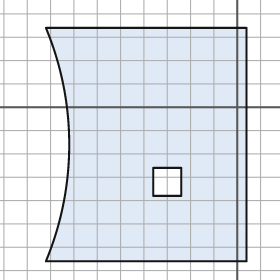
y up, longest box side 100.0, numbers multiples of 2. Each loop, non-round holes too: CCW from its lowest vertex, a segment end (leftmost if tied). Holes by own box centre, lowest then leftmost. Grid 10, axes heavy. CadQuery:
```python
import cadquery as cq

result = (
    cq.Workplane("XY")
    .moveTo(-82.0, -66.0)
    .lineTo(4.0, -66.0)
    .lineTo(4.0, 34.0)
    .lineTo(-82.0, 34.0)
    .threePointArc((-72.0, -16.0), (-82.0, -66.0))
    .close()
    .moveTo(-36.0, -38.0)
    .lineTo(-24.0, -38.0)
    .lineTo(-24.0, -26.0)
    .lineTo(-36.0, -26.0)
    .close()
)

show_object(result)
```